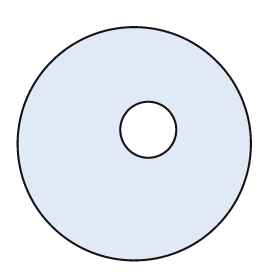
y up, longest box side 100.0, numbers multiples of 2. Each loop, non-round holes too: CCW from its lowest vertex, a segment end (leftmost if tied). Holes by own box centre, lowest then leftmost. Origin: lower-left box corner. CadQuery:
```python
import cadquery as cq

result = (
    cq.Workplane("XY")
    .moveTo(50.0, 50.0)
    .circle(50.0)
    .moveTo(56.0, 56.0)
    .circle(12.0)
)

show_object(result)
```